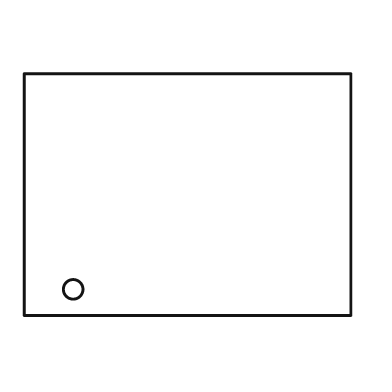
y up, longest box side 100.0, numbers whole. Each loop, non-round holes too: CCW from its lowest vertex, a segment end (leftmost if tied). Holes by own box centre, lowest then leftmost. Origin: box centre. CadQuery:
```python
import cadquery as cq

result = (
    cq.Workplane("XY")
    .moveTo(-50.0, -37.0)
    .lineTo(50.0, -37.0)
    .lineTo(50.0, 37.0)
    .lineTo(-50.0, 37.0)
    .close()
    .moveTo(-35.0, -29.0)
    .circle(3.0)
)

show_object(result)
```